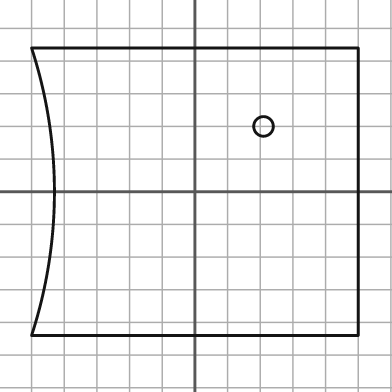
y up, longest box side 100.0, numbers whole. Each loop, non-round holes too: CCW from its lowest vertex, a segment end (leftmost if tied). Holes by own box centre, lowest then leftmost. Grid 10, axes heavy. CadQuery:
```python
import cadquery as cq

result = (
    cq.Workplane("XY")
    .moveTo(-50.0, -44.0)
    .lineTo(50.0, -44.0)
    .lineTo(50.0, 44.0)
    .lineTo(-50.0, 44.0)
    .threePointArc((-43.0, 0.0), (-50.0, -44.0))
    .close()
    .moveTo(21.0, 20.0)
    .circle(3.0)
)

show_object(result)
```